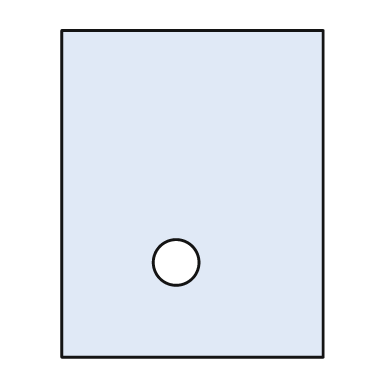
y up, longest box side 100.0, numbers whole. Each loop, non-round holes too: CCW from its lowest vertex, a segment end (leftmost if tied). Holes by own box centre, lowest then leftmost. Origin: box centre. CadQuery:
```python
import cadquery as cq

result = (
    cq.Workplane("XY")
    .moveTo(-40.0, -50.0)
    .lineTo(40.0, -50.0)
    .lineTo(40.0, 50.0)
    .lineTo(-40.0, 50.0)
    .close()
    .moveTo(-5.0, -21.0)
    .circle(7.0)
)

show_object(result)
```